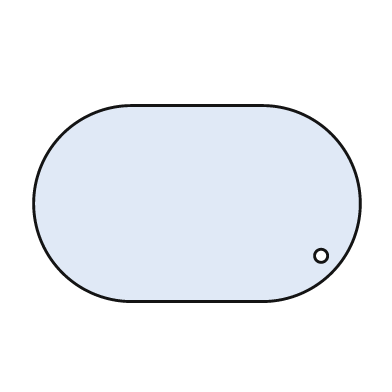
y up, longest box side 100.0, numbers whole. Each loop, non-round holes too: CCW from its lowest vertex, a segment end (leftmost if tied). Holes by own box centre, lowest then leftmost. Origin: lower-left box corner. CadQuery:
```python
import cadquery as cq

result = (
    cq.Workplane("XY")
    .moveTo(30.0, 0.0)
    .lineTo(70.0, 0.0)
    .threePointArc((100.0, 30.0), (70.0, 60.0))
    .lineTo(30.0, 60.0)
    .threePointArc((0.0, 30.0), (30.0, 0.0))
    .close()
    .moveTo(88.0, 14.0)
    .circle(2.0)
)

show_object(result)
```